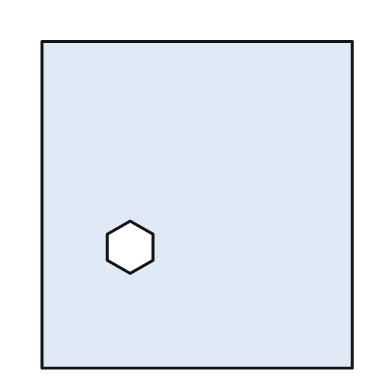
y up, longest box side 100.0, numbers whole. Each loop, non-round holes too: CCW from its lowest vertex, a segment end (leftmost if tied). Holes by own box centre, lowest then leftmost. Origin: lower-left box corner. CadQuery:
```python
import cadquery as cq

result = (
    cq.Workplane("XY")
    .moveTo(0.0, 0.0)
    .lineTo(95.0, 0.0)
    .lineTo(95.0, 100.0)
    .lineTo(0.0, 100.0)
    .close()
    .moveTo(27.0, 29.0)
    .lineTo(34.0, 33.0)
    .lineTo(34.0, 41.0)
    .lineTo(27.0, 45.0)
    .lineTo(20.0, 41.0)
    .lineTo(20.0, 33.0)
    .close()
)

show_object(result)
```